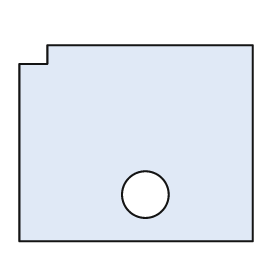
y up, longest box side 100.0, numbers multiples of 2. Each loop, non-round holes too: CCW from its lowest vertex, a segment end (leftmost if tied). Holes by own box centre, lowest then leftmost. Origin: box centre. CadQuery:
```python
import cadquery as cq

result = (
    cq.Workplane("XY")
    .moveTo(-50.0, -42.0)
    .lineTo(50.0, -42.0)
    .lineTo(50.0, 42.0)
    .lineTo(-38.0, 42.0)
    .lineTo(-38.0, 34.0)
    .lineTo(-50.0, 34.0)
    .close()
    .moveTo(4.0, -22.0)
    .circle(10.0)
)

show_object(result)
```